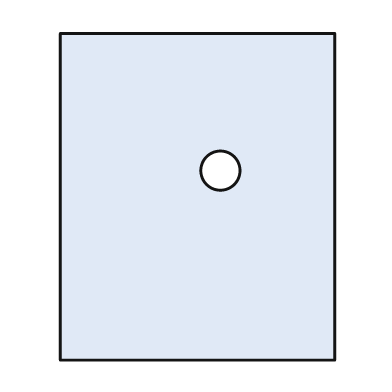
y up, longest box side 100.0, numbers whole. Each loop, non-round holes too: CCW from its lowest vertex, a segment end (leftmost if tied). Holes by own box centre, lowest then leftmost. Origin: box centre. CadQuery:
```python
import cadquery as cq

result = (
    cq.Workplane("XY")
    .moveTo(-42.0, -50.0)
    .lineTo(42.0, -50.0)
    .lineTo(42.0, 50.0)
    .lineTo(-42.0, 50.0)
    .close()
    .moveTo(7.0, 8.0)
    .circle(6.0)
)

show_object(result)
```